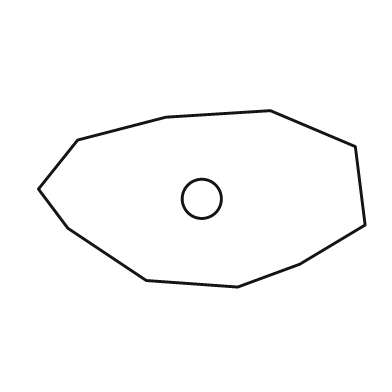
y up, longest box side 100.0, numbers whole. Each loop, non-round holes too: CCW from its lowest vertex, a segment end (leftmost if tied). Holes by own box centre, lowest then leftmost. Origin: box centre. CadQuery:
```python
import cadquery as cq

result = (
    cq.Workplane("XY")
    .moveTo(11.0, -27.0)
    .lineTo(30.0, -20.0)
    .lineTo(50.0, -8.0)
    .lineTo(47.0, 16.0)
    .lineTo(21.0, 27.0)
    .lineTo(-11.0, 25.0)
    .lineTo(-38.0, 18.0)
    .lineTo(-50.0, 3.0)
    .lineTo(-41.0, -9.0)
    .lineTo(-17.0, -25.0)
    .close()
    .moveTo(0.0, 0.0)
    .circle(6.0)
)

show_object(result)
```